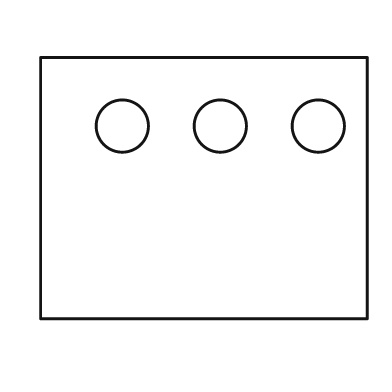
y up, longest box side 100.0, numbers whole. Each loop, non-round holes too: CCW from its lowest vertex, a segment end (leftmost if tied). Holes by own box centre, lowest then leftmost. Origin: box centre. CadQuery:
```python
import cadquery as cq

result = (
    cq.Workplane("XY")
    .moveTo(-50.0, -40.0)
    .lineTo(50.0, -40.0)
    .lineTo(50.0, 40.0)
    .lineTo(-50.0, 40.0)
    .close()
    .moveTo(-25.0, 19.0)
    .circle(8.0)
    .moveTo(5.0, 19.0)
    .circle(8.0)
    .moveTo(35.0, 19.0)
    .circle(8.0)
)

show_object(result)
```